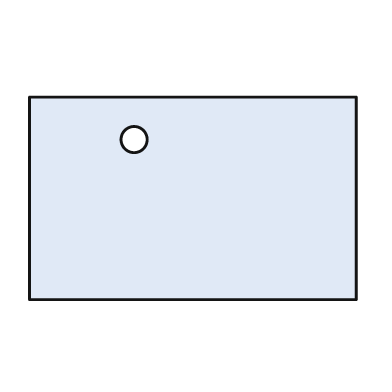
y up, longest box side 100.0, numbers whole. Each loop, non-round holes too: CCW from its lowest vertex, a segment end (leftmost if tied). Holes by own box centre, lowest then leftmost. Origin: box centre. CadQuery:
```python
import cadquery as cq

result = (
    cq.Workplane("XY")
    .moveTo(-50.0, -31.0)
    .lineTo(50.0, -31.0)
    .lineTo(50.0, 31.0)
    .lineTo(-50.0, 31.0)
    .close()
    .moveTo(-18.0, 18.0)
    .circle(4.0)
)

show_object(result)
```